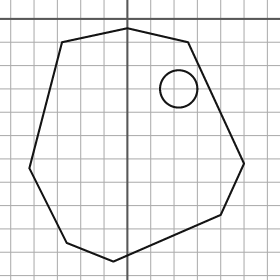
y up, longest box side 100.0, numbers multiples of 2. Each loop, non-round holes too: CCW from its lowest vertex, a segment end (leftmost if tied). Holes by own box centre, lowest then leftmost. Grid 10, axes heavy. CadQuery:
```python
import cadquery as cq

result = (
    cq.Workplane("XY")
    .moveTo(-6.0, -104.0)
    .lineTo(40.0, -84.0)
    .lineTo(50.0, -62.0)
    .lineTo(26.0, -10.0)
    .lineTo(0.0, -4.0)
    .lineTo(-28.0, -10.0)
    .lineTo(-42.0, -64.0)
    .lineTo(-26.0, -96.0)
    .close()
    .moveTo(22.0, -30.0)
    .circle(8.0)
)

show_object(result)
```